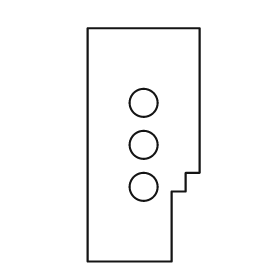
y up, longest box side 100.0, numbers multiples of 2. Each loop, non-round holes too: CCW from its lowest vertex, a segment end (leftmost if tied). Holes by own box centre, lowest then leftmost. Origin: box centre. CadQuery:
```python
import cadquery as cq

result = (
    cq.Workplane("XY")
    .moveTo(-24.0, -50.0)
    .lineTo(12.0, -50.0)
    .lineTo(12.0, -20.0)
    .lineTo(18.0, -20.0)
    .lineTo(18.0, -12.0)
    .lineTo(24.0, -12.0)
    .lineTo(24.0, 50.0)
    .lineTo(-24.0, 50.0)
    .close()
    .moveTo(0.0, -18.0)
    .circle(6.0)
    .moveTo(0.0, 0.0)
    .circle(6.0)
    .moveTo(0.0, 18.0)
    .circle(6.0)
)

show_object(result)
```